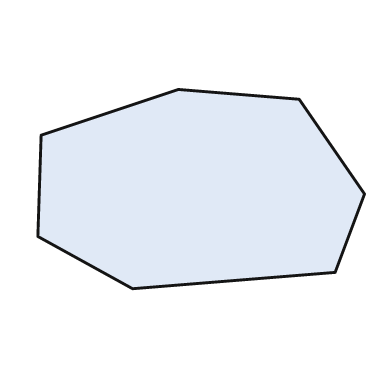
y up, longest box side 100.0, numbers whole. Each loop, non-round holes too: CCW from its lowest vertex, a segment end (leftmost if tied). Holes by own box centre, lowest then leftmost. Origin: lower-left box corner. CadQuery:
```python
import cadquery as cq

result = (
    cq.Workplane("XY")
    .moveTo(29.0, 0.0)
    .lineTo(91.0, 5.0)
    .lineTo(100.0, 29.0)
    .lineTo(80.0, 58.0)
    .lineTo(43.0, 61.0)
    .lineTo(1.0, 47.0)
    .lineTo(0.0, 16.0)
    .close()
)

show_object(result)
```